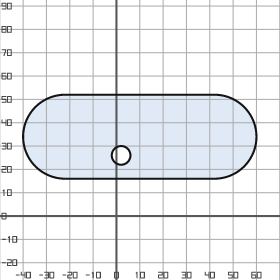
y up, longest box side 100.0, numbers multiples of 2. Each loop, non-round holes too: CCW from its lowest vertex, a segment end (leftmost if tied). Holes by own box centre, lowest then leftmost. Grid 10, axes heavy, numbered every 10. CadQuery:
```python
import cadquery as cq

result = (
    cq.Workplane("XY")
    .moveTo(-22.0, 16.0)
    .lineTo(42.0, 16.0)
    .threePointArc((60.0, 34.0), (42.0, 52.0))
    .lineTo(-22.0, 52.0)
    .threePointArc((-40.0, 34.0), (-22.0, 16.0))
    .close()
    .moveTo(2.0, 26.0)
    .circle(4.0)
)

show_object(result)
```